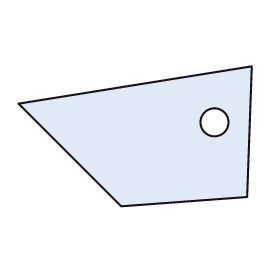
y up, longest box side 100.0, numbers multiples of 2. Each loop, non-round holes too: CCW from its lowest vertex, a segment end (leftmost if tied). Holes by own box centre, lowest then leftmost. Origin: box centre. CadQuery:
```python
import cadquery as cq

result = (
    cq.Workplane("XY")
    .moveTo(-6.0, -30.0)
    .lineTo(48.0, -26.0)
    .lineTo(50.0, 30.0)
    .lineTo(-50.0, 14.0)
    .close()
    .moveTo(34.0, 6.0)
    .circle(6.0)
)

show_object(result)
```